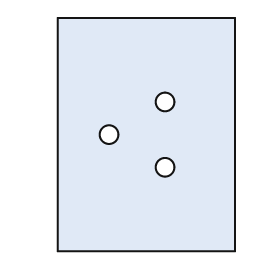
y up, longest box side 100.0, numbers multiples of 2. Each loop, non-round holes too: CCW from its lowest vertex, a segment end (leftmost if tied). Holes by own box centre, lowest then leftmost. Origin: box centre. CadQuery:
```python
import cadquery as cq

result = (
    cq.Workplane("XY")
    .moveTo(-38.0, -50.0)
    .lineTo(38.0, -50.0)
    .lineTo(38.0, 50.0)
    .lineTo(-38.0, 50.0)
    .close()
    .moveTo(8.0, -14.0)
    .circle(4.0)
    .moveTo(-16.0, 0.0)
    .circle(4.0)
    .moveTo(8.0, 14.0)
    .circle(4.0)
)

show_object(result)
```